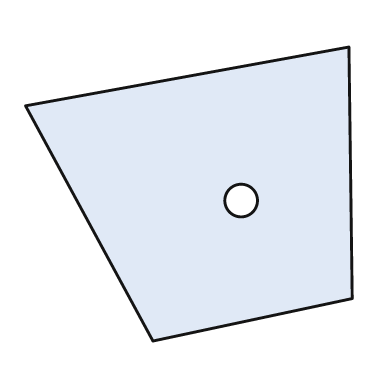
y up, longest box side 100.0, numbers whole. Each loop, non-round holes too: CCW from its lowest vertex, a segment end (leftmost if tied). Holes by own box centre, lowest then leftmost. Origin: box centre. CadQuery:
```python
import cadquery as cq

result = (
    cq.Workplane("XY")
    .moveTo(-11.0, -45.0)
    .lineTo(50.0, -32.0)
    .lineTo(49.0, 45.0)
    .lineTo(-50.0, 27.0)
    .close()
    .moveTo(16.0, -2.0)
    .circle(5.0)
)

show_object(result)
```